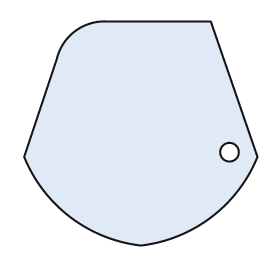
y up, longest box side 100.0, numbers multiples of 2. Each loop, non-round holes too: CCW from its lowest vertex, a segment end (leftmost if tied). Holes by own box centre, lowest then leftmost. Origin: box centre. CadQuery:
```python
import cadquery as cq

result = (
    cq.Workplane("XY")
    .moveTo(0.0, -48.0)
    .threePointArc((30.0, -36.0), (50.0, -10.0))
    .lineTo(30.0, 48.0)
    .lineTo(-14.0, 48.0)
    .threePointArc((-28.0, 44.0), (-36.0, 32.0))
    .lineTo(-50.0, -10.0)
    .threePointArc((-30.0, -36.0), (0.0, -48.0))
    .close()
    .moveTo(38.0, -8.0)
    .circle(4.0)
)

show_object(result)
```